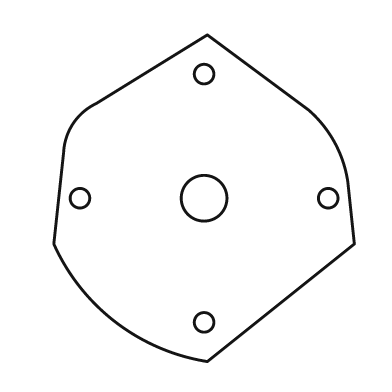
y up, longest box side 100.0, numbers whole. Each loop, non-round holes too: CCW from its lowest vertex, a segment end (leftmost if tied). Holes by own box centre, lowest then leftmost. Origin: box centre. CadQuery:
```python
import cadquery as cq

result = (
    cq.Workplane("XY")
    .moveTo(1.0, -50.0)
    .lineTo(46.0, -14.0)
    .lineTo(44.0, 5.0)
    .threePointArc((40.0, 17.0), (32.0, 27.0))
    .lineTo(1.0, 50.0)
    .lineTo(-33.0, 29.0)
    .threePointArc((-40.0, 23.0), (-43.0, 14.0))
    .lineTo(-46.0, -14.0)
    .threePointArc((-27.0, -38.0), (1.0, -50.0))
    .close()
    .moveTo(0.0, -38.0)
    .circle(3.0)
    .moveTo(-38.0, 0.0)
    .circle(3.0)
    .moveTo(0.0, 0.0)
    .circle(7.0)
    .moveTo(38.0, 0.0)
    .circle(3.0)
    .moveTo(0.0, 38.0)
    .circle(3.0)
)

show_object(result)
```